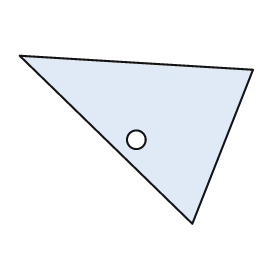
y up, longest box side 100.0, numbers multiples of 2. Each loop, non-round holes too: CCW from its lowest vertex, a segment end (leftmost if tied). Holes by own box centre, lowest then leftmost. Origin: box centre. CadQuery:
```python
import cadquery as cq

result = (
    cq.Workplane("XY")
    .moveTo(24.0, -36.0)
    .lineTo(50.0, 30.0)
    .lineTo(-50.0, 36.0)
    .close()
    .moveTo(0.0, 0.0)
    .circle(4.0)
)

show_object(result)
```